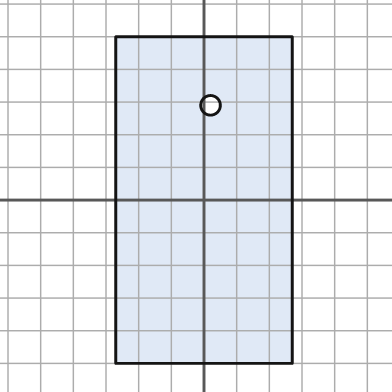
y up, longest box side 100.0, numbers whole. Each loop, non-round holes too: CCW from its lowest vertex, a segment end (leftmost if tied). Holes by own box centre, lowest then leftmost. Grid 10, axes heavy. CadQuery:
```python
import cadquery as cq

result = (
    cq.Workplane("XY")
    .moveTo(-27.0, -50.0)
    .lineTo(27.0, -50.0)
    .lineTo(27.0, 50.0)
    .lineTo(-27.0, 50.0)
    .close()
    .moveTo(2.0, 29.0)
    .circle(3.0)
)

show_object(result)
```